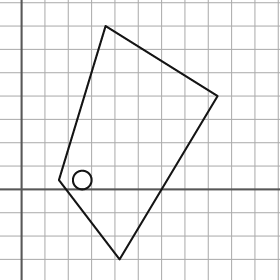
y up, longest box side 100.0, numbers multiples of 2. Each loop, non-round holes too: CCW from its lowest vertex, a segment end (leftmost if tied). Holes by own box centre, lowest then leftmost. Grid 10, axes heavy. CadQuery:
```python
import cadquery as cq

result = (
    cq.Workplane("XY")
    .moveTo(42.0, -30.0)
    .lineTo(84.0, 40.0)
    .lineTo(36.0, 70.0)
    .lineTo(16.0, 4.0)
    .close()
    .moveTo(26.0, 4.0)
    .circle(4.0)
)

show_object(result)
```